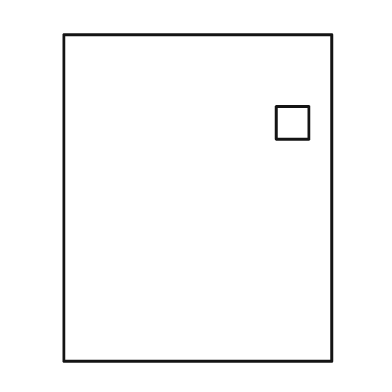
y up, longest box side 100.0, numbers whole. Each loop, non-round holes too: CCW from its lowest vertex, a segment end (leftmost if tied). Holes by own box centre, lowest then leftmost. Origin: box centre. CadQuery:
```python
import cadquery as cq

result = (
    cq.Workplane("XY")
    .moveTo(-41.0, -50.0)
    .lineTo(41.0, -50.0)
    .lineTo(41.0, 50.0)
    .lineTo(-41.0, 50.0)
    .close()
    .moveTo(24.0, 18.0)
    .lineTo(34.0, 18.0)
    .lineTo(34.0, 28.0)
    .lineTo(24.0, 28.0)
    .close()
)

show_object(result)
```